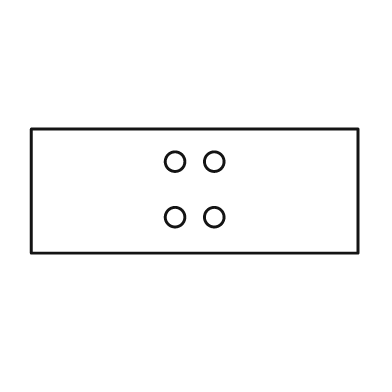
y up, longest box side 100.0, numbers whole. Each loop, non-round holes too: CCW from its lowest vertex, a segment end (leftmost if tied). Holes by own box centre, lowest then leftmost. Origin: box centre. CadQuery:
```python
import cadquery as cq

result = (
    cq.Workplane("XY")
    .moveTo(-50.0, -19.0)
    .lineTo(50.0, -19.0)
    .lineTo(50.0, 19.0)
    .lineTo(-50.0, 19.0)
    .close()
    .moveTo(-6.0, -8.0)
    .circle(3.0)
    .moveTo(6.0, -8.0)
    .circle(3.0)
    .moveTo(-6.0, 9.0)
    .circle(3.0)
    .moveTo(6.0, 9.0)
    .circle(3.0)
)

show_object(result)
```